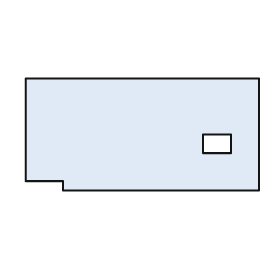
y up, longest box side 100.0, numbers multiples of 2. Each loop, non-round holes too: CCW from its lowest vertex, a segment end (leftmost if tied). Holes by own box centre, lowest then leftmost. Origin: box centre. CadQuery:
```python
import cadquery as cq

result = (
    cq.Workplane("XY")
    .moveTo(-34.0, -24.0)
    .lineTo(50.0, -24.0)
    .lineTo(50.0, 24.0)
    .lineTo(-50.0, 24.0)
    .lineTo(-50.0, -20.0)
    .lineTo(-34.0, -20.0)
    .close()
    .moveTo(26.0, -8.0)
    .lineTo(38.0, -8.0)
    .lineTo(38.0, 0.0)
    .lineTo(26.0, 0.0)
    .close()
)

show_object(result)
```